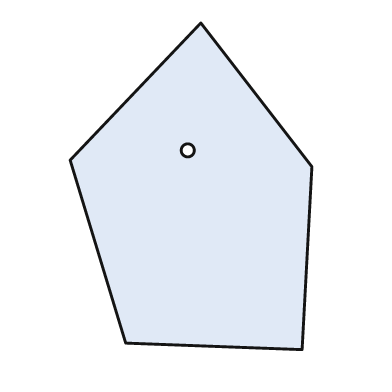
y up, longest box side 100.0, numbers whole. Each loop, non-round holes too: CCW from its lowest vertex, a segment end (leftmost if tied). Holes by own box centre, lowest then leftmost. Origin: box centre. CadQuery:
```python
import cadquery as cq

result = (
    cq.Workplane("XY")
    .moveTo(34.0, -50.0)
    .lineTo(37.0, 6.0)
    .lineTo(3.0, 50.0)
    .lineTo(-37.0, 8.0)
    .lineTo(-20.0, -48.0)
    .close()
    .moveTo(-1.0, 11.0)
    .circle(2.0)
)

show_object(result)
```